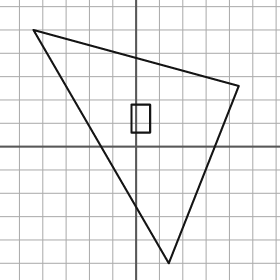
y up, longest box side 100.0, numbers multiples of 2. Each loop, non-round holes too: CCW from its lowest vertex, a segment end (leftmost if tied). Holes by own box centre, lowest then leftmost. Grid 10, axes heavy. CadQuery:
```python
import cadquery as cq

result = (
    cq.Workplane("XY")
    .moveTo(14.0, -50.0)
    .lineTo(44.0, 26.0)
    .lineTo(-44.0, 50.0)
    .close()
    .moveTo(-2.0, 6.0)
    .lineTo(6.0, 6.0)
    .lineTo(6.0, 18.0)
    .lineTo(-2.0, 18.0)
    .close()
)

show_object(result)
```